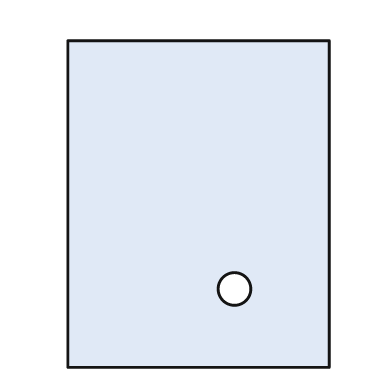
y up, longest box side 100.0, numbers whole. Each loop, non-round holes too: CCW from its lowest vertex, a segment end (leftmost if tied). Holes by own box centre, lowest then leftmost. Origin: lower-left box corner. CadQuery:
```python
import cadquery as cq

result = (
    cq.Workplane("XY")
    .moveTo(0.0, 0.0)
    .lineTo(80.0, 0.0)
    .lineTo(80.0, 100.0)
    .lineTo(0.0, 100.0)
    .close()
    .moveTo(51.0, 24.0)
    .circle(5.0)
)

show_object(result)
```